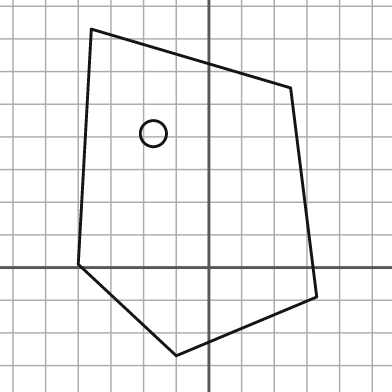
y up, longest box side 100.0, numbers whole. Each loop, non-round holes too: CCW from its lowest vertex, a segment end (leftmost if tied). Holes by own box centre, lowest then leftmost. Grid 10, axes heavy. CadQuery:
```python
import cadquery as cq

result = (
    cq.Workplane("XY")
    .moveTo(-10.0, -27.0)
    .lineTo(33.0, -9.0)
    .lineTo(25.0, 55.0)
    .lineTo(-36.0, 73.0)
    .lineTo(-40.0, 1.0)
    .close()
    .moveTo(-17.0, 41.0)
    .circle(4.0)
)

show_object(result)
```